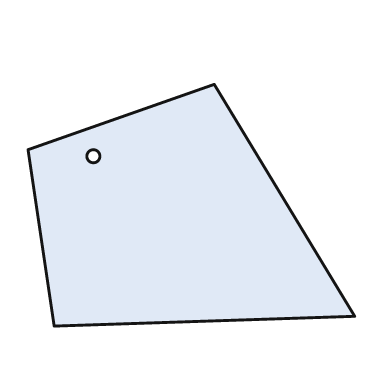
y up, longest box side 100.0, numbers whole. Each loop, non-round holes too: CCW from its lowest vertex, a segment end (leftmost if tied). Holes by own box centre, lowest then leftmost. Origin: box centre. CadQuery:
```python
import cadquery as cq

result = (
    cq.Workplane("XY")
    .moveTo(-42.0, -37.0)
    .lineTo(50.0, -34.0)
    .lineTo(7.0, 37.0)
    .lineTo(-50.0, 17.0)
    .close()
    .moveTo(-30.0, 15.0)
    .circle(2.0)
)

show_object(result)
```